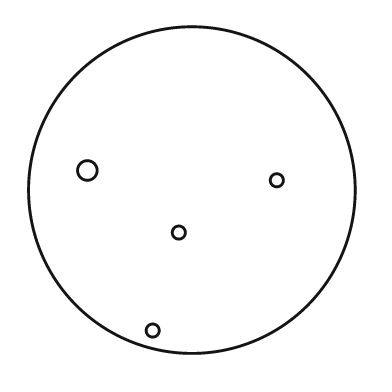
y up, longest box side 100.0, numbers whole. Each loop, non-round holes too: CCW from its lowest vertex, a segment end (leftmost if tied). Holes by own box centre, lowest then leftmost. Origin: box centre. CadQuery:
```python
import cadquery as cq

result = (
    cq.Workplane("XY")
    .moveTo(0.0, 0.0)
    .circle(50.0)
    .moveTo(-12.0, -43.0)
    .circle(2.0)
    .moveTo(-4.0, -13.0)
    .circle(2.0)
    .moveTo(26.0, 3.0)
    .circle(2.0)
    .moveTo(-32.0, 6.0)
    .circle(3.0)
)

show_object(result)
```